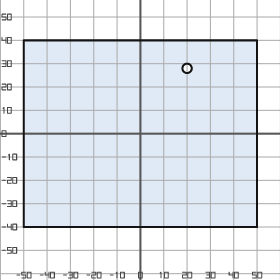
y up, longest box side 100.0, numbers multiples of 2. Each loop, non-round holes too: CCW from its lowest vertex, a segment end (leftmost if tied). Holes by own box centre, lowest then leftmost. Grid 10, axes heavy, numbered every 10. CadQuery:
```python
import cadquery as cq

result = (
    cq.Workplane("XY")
    .moveTo(-50.0, -40.0)
    .lineTo(50.0, -40.0)
    .lineTo(50.0, 40.0)
    .lineTo(-50.0, 40.0)
    .close()
    .moveTo(20.0, 28.0)
    .circle(2.0)
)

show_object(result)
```